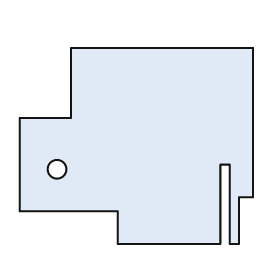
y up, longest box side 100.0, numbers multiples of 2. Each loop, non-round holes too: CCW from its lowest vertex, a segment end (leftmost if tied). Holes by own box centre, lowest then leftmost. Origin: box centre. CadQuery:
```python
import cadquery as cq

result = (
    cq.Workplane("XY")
    .moveTo(-8.0, -42.0)
    .lineTo(36.0, -42.0)
    .lineTo(36.0, -8.0)
    .lineTo(40.0, -8.0)
    .lineTo(40.0, -42.0)
    .lineTo(44.0, -42.0)
    .lineTo(44.0, -22.0)
    .lineTo(50.0, -22.0)
    .lineTo(50.0, 42.0)
    .lineTo(-28.0, 42.0)
    .lineTo(-28.0, 12.0)
    .lineTo(-50.0, 12.0)
    .lineTo(-50.0, -28.0)
    .lineTo(-8.0, -28.0)
    .close()
    .moveTo(-34.0, -10.0)
    .circle(4.0)
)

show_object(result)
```